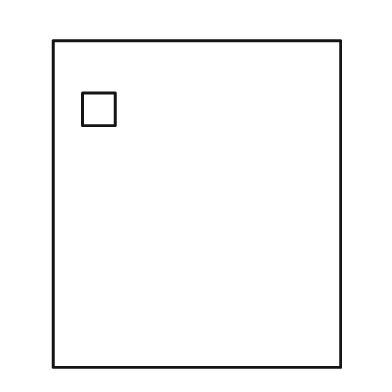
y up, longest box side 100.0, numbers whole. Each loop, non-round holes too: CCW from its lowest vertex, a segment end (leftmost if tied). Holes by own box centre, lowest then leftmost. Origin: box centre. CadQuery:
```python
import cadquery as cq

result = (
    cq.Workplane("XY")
    .moveTo(-44.0, -50.0)
    .lineTo(44.0, -50.0)
    .lineTo(44.0, 50.0)
    .lineTo(-44.0, 50.0)
    .close()
    .moveTo(-35.0, 24.0)
    .lineTo(-25.0, 24.0)
    .lineTo(-25.0, 34.0)
    .lineTo(-35.0, 34.0)
    .close()
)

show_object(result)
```